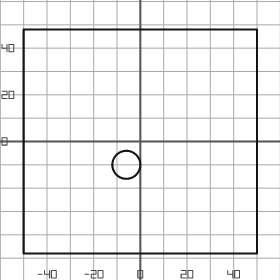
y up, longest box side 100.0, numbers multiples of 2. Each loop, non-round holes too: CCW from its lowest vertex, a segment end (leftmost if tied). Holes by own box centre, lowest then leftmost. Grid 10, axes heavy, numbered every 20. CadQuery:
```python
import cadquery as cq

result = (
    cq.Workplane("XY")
    .moveTo(-50.0, -48.0)
    .lineTo(50.0, -48.0)
    .lineTo(50.0, 48.0)
    .lineTo(-50.0, 48.0)
    .close()
    .moveTo(-6.0, -10.0)
    .circle(6.0)
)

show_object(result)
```